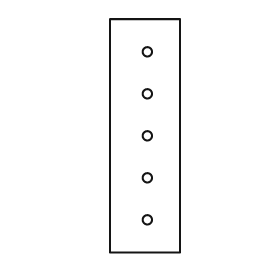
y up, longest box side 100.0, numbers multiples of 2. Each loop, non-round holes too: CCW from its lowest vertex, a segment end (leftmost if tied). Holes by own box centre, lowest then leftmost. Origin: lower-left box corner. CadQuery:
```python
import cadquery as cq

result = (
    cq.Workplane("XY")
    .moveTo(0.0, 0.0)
    .lineTo(30.0, 0.0)
    .lineTo(30.0, 100.0)
    .lineTo(0.0, 100.0)
    .close()
    .moveTo(16.0, 14.0)
    .circle(2.0)
    .moveTo(16.0, 32.0)
    .circle(2.0)
    .moveTo(16.0, 50.0)
    .circle(2.0)
    .moveTo(16.0, 68.0)
    .circle(2.0)
    .moveTo(16.0, 86.0)
    .circle(2.0)
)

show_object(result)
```